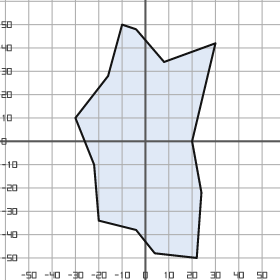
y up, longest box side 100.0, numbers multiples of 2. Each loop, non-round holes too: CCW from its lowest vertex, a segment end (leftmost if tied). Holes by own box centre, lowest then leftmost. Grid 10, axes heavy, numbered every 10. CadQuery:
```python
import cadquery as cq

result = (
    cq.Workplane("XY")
    .moveTo(22.0, -50.0)
    .lineTo(24.0, -22.0)
    .lineTo(20.0, 0.0)
    .lineTo(30.0, 42.0)
    .lineTo(8.0, 34.0)
    .lineTo(-4.0, 48.0)
    .lineTo(-10.0, 50.0)
    .lineTo(-16.0, 28.0)
    .lineTo(-30.0, 10.0)
    .lineTo(-22.0, -10.0)
    .lineTo(-20.0, -34.0)
    .lineTo(-4.0, -38.0)
    .lineTo(4.0, -48.0)
    .close()
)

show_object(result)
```